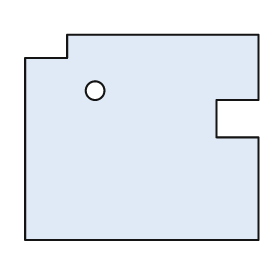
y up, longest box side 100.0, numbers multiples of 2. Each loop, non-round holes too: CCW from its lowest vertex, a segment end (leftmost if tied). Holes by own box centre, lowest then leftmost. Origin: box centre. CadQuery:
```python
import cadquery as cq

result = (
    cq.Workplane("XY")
    .moveTo(-50.0, -44.0)
    .lineTo(50.0, -44.0)
    .lineTo(50.0, 0.0)
    .lineTo(32.0, 0.0)
    .lineTo(32.0, 16.0)
    .lineTo(50.0, 16.0)
    .lineTo(50.0, 44.0)
    .lineTo(-32.0, 44.0)
    .lineTo(-32.0, 34.0)
    .lineTo(-50.0, 34.0)
    .close()
    .moveTo(-20.0, 20.0)
    .circle(4.0)
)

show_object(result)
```